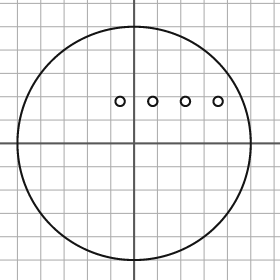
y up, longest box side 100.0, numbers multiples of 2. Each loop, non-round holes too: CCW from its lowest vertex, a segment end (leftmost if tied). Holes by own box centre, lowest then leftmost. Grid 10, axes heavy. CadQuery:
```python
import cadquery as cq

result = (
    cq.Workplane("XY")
    .moveTo(0.0, 0.0)
    .circle(50.0)
    .moveTo(-6.0, 18.0)
    .circle(2.0)
    .moveTo(8.0, 18.0)
    .circle(2.0)
    .moveTo(22.0, 18.0)
    .circle(2.0)
    .moveTo(36.0, 18.0)
    .circle(2.0)
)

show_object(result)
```